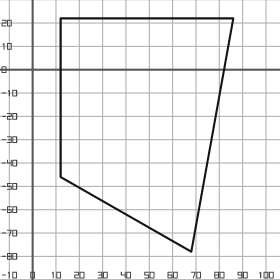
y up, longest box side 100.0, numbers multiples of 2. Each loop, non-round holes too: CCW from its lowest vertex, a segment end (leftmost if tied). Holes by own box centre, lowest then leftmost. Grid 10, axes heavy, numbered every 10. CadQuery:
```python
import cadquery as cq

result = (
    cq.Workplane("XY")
    .moveTo(68.0, -78.0)
    .lineTo(86.0, 22.0)
    .lineTo(12.0, 22.0)
    .lineTo(12.0, -46.0)
    .close()
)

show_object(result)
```